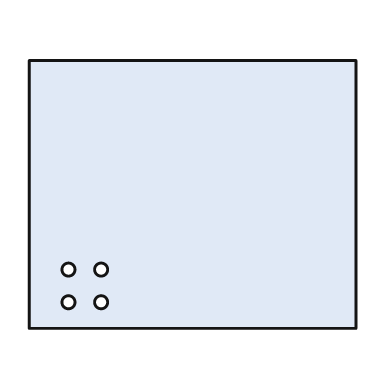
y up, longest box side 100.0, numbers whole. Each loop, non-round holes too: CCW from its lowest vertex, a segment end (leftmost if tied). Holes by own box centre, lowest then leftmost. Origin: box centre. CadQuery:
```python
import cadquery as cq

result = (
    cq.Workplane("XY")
    .moveTo(-50.0, -41.0)
    .lineTo(50.0, -41.0)
    .lineTo(50.0, 41.0)
    .lineTo(-50.0, 41.0)
    .close()
    .moveTo(-38.0, -33.0)
    .circle(2.0)
    .moveTo(-28.0, -33.0)
    .circle(2.0)
    .moveTo(-38.0, -23.0)
    .circle(2.0)
    .moveTo(-28.0, -23.0)
    .circle(2.0)
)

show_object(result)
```